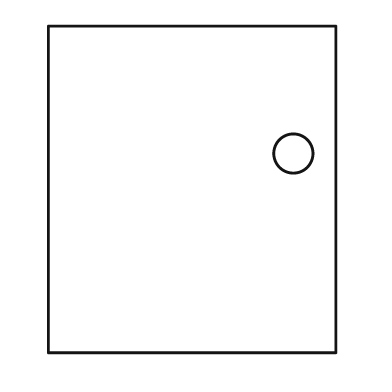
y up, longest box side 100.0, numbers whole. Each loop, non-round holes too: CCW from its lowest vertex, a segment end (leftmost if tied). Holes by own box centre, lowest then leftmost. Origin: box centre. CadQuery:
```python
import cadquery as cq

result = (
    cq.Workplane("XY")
    .moveTo(-44.0, -50.0)
    .lineTo(44.0, -50.0)
    .lineTo(44.0, 50.0)
    .lineTo(-44.0, 50.0)
    .close()
    .moveTo(31.0, 11.0)
    .circle(6.0)
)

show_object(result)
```